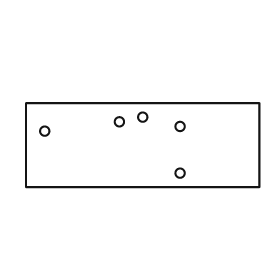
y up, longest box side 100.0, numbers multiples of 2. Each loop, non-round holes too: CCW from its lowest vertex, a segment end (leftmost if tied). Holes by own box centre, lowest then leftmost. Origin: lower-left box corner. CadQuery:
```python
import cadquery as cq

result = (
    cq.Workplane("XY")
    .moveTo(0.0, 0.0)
    .lineTo(100.0, 0.0)
    .lineTo(100.0, 36.0)
    .lineTo(0.0, 36.0)
    .close()
    .moveTo(66.0, 6.0)
    .circle(2.0)
    .moveTo(8.0, 24.0)
    .circle(2.0)
    .moveTo(66.0, 26.0)
    .circle(2.0)
    .moveTo(40.0, 28.0)
    .circle(2.0)
    .moveTo(50.0, 30.0)
    .circle(2.0)
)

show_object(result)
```